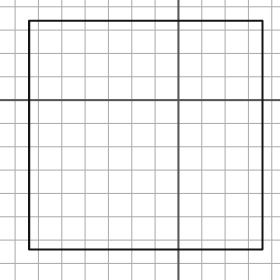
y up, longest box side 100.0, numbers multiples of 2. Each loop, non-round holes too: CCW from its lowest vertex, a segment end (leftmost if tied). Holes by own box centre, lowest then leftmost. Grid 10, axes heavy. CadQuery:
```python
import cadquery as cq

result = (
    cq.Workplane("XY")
    .moveTo(-64.0, -64.0)
    .lineTo(36.0, -64.0)
    .lineTo(36.0, 34.0)
    .lineTo(-64.0, 34.0)
    .close()
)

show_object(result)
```